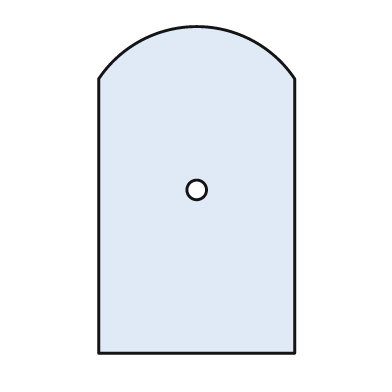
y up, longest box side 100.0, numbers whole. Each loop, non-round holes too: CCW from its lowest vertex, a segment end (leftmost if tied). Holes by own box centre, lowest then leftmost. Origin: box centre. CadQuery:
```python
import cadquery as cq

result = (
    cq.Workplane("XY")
    .moveTo(-30.0, -50.0)
    .lineTo(30.0, -50.0)
    .lineTo(30.0, 34.0)
    .threePointArc((0.0, 50.0), (-30.0, 34.0))
    .close()
    .moveTo(0.0, 0.0)
    .circle(3.0)
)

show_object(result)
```